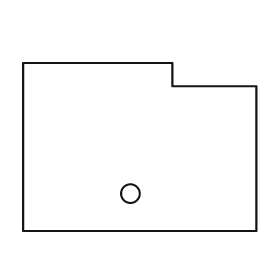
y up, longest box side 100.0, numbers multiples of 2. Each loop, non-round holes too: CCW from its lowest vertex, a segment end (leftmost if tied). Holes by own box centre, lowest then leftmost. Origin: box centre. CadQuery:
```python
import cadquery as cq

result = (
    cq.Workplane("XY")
    .moveTo(-50.0, -36.0)
    .lineTo(50.0, -36.0)
    .lineTo(50.0, 26.0)
    .lineTo(14.0, 26.0)
    .lineTo(14.0, 36.0)
    .lineTo(-50.0, 36.0)
    .close()
    .moveTo(-4.0, -20.0)
    .circle(4.0)
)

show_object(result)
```